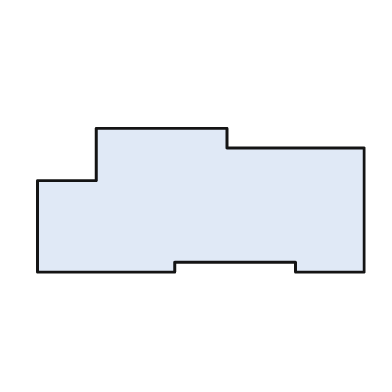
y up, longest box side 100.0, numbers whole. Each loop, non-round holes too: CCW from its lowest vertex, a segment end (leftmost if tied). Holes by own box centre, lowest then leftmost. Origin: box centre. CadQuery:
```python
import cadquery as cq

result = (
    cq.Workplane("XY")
    .moveTo(-50.0, -22.0)
    .lineTo(-8.0, -22.0)
    .lineTo(-8.0, -19.0)
    .lineTo(29.0, -19.0)
    .lineTo(29.0, -22.0)
    .lineTo(50.0, -22.0)
    .lineTo(50.0, 16.0)
    .lineTo(8.0, 16.0)
    .lineTo(8.0, 22.0)
    .lineTo(-32.0, 22.0)
    .lineTo(-32.0, 6.0)
    .lineTo(-50.0, 6.0)
    .close()
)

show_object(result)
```